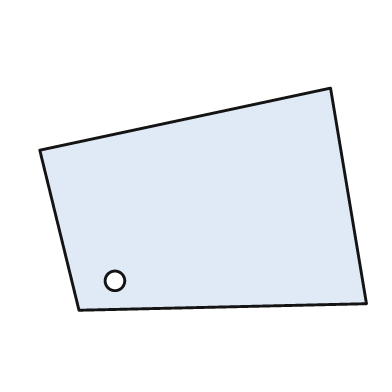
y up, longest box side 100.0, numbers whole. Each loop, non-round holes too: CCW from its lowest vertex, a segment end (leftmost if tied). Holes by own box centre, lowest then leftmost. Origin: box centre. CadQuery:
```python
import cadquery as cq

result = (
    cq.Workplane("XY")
    .moveTo(-38.0, -34.0)
    .lineTo(50.0, -32.0)
    .lineTo(39.0, 34.0)
    .lineTo(-50.0, 15.0)
    .close()
    .moveTo(-27.0, -25.0)
    .circle(3.0)
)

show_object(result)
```